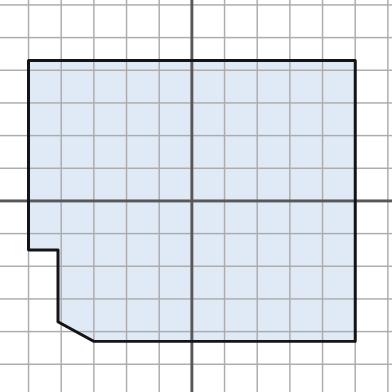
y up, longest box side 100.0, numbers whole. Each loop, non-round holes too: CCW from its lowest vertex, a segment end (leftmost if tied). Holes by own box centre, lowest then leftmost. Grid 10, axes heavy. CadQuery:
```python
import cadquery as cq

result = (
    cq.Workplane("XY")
    .moveTo(-30.0, -43.0)
    .lineTo(50.0, -43.0)
    .lineTo(50.0, 43.0)
    .lineTo(-50.0, 43.0)
    .lineTo(-50.0, -15.0)
    .lineTo(-41.0, -15.0)
    .lineTo(-41.0, -37.0)
    .close()
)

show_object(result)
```